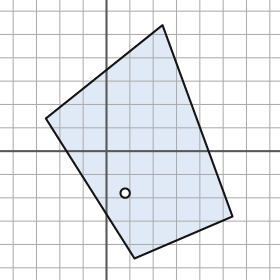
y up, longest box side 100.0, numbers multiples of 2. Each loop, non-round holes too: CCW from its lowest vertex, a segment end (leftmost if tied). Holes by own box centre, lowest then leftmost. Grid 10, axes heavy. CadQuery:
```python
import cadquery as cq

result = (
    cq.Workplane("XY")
    .moveTo(12.0, -46.0)
    .lineTo(54.0, -28.0)
    .lineTo(24.0, 54.0)
    .lineTo(-26.0, 14.0)
    .close()
    .moveTo(8.0, -18.0)
    .circle(2.0)
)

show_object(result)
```